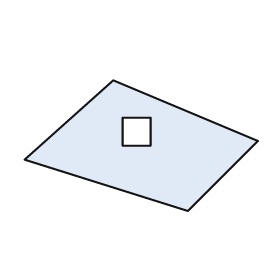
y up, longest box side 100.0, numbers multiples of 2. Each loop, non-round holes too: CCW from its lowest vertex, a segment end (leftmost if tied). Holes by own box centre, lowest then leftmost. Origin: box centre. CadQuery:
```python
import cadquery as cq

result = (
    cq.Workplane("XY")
    .moveTo(20.0, -28.0)
    .lineTo(50.0, 2.0)
    .lineTo(-12.0, 28.0)
    .lineTo(-50.0, -6.0)
    .close()
    .moveTo(-8.0, 0.0)
    .lineTo(4.0, 0.0)
    .lineTo(4.0, 12.0)
    .lineTo(-8.0, 12.0)
    .close()
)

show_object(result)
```